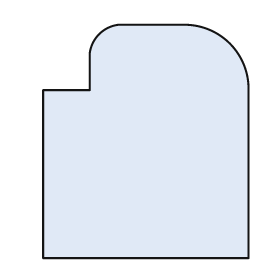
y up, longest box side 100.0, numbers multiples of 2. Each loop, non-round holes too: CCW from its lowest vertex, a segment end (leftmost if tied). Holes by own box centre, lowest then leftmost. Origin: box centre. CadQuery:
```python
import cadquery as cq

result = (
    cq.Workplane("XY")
    .moveTo(-44.0, -50.0)
    .lineTo(44.0, -50.0)
    .lineTo(44.0, 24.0)
    .threePointArc((36.0, 42.0), (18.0, 50.0))
    .lineTo(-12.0, 50.0)
    .threePointArc((-20.0, 46.0), (-24.0, 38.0))
    .lineTo(-24.0, 22.0)
    .lineTo(-44.0, 22.0)
    .close()
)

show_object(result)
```